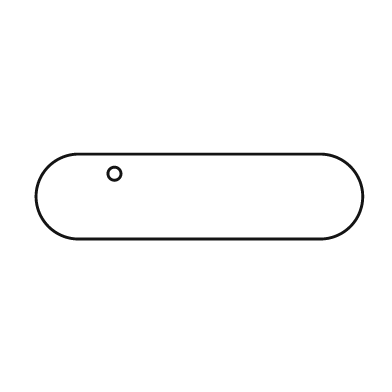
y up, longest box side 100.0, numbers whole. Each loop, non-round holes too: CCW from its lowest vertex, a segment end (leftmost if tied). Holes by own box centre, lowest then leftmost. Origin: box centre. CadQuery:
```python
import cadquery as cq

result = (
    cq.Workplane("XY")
    .moveTo(-37.0, -13.0)
    .lineTo(37.0, -13.0)
    .threePointArc((50.0, 0.0), (37.0, 13.0))
    .lineTo(-37.0, 13.0)
    .threePointArc((-50.0, 0.0), (-37.0, -13.0))
    .close()
    .moveTo(-26.0, 7.0)
    .circle(2.0)
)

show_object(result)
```